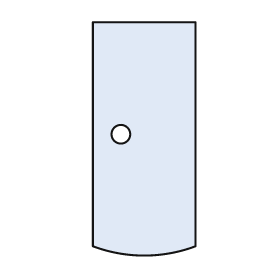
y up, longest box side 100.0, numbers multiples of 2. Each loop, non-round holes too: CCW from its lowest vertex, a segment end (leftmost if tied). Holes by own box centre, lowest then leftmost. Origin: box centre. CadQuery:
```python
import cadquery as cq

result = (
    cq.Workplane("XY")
    .moveTo(-22.0, -46.0)
    .threePointArc((0.0, -50.0), (22.0, -46.0))
    .lineTo(22.0, 50.0)
    .lineTo(-22.0, 50.0)
    .close()
    .moveTo(-10.0, 2.0)
    .circle(4.0)
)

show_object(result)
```